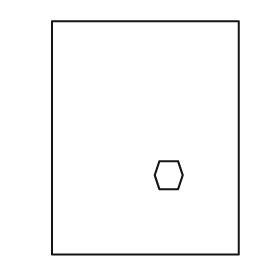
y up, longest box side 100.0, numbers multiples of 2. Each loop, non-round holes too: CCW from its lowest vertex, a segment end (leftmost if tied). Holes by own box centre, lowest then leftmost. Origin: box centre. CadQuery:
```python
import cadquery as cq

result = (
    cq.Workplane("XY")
    .moveTo(-40.0, -50.0)
    .lineTo(40.0, -50.0)
    .lineTo(40.0, 50.0)
    .lineTo(-40.0, 50.0)
    .close()
    .moveTo(6.0, -22.0)
    .lineTo(14.0, -22.0)
    .lineTo(16.0, -16.0)
    .lineTo(14.0, -10.0)
    .lineTo(6.0, -10.0)
    .lineTo(4.0, -16.0)
    .close()
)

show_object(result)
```